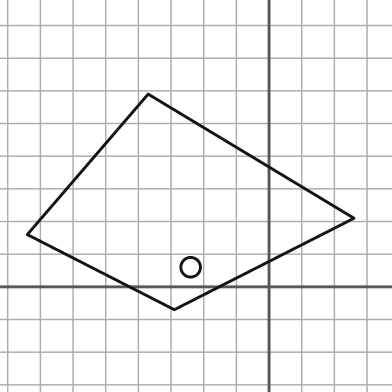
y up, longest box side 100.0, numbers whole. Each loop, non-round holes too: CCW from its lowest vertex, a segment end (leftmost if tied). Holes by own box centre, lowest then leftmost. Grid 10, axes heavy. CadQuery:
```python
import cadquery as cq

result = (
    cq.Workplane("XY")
    .moveTo(-29.0, -7.0)
    .lineTo(26.0, 21.0)
    .lineTo(-37.0, 59.0)
    .lineTo(-74.0, 16.0)
    .close()
    .moveTo(-24.0, 6.0)
    .circle(3.0)
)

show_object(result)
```